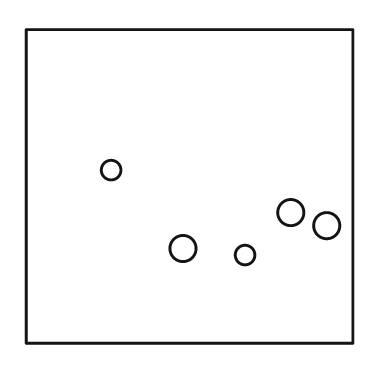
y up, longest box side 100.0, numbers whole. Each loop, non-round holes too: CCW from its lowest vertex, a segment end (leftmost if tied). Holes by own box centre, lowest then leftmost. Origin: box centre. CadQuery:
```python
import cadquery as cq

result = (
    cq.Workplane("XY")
    .moveTo(-50.0, -48.0)
    .lineTo(50.0, -48.0)
    .lineTo(50.0, 48.0)
    .lineTo(-50.0, 48.0)
    .close()
    .moveTo(17.0, -21.0)
    .circle(3.0)
    .moveTo(-2.0, -19.0)
    .circle(4.0)
    .moveTo(42.0, -12.0)
    .circle(4.0)
    .moveTo(31.0, -8.0)
    .circle(4.0)
    .moveTo(-24.0, 5.0)
    .circle(3.0)
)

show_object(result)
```